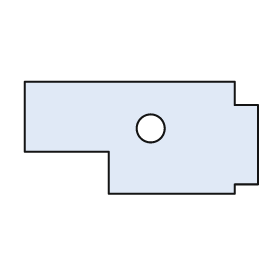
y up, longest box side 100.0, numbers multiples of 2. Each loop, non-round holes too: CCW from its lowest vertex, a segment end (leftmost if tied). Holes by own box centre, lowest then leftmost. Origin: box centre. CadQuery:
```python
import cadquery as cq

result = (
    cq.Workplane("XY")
    .moveTo(-14.0, -24.0)
    .lineTo(40.0, -24.0)
    .lineTo(40.0, -20.0)
    .lineTo(50.0, -20.0)
    .lineTo(50.0, 14.0)
    .lineTo(40.0, 14.0)
    .lineTo(40.0, 24.0)
    .lineTo(-50.0, 24.0)
    .lineTo(-50.0, -6.0)
    .lineTo(-14.0, -6.0)
    .close()
    .moveTo(4.0, 4.0)
    .circle(6.0)
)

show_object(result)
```